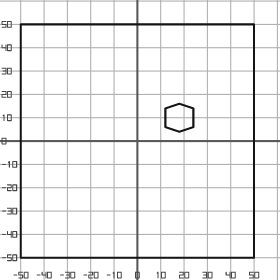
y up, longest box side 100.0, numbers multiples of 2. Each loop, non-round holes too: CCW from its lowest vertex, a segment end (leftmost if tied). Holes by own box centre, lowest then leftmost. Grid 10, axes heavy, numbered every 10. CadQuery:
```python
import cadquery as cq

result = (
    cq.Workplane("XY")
    .moveTo(-50.0, -50.0)
    .lineTo(50.0, -50.0)
    .lineTo(50.0, 50.0)
    .lineTo(-50.0, 50.0)
    .close()
    .moveTo(18.0, 4.0)
    .lineTo(24.0, 6.0)
    .lineTo(24.0, 14.0)
    .lineTo(18.0, 16.0)
    .lineTo(12.0, 14.0)
    .lineTo(12.0, 6.0)
    .close()
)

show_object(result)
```